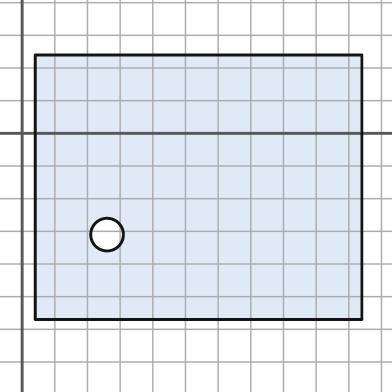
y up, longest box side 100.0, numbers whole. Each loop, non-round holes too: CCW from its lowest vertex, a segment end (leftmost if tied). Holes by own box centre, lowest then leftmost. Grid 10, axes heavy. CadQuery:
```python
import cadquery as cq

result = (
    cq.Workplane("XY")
    .moveTo(4.0, -57.0)
    .lineTo(104.0, -57.0)
    .lineTo(104.0, 24.0)
    .lineTo(4.0, 24.0)
    .close()
    .moveTo(26.0, -31.0)
    .circle(5.0)
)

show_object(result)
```